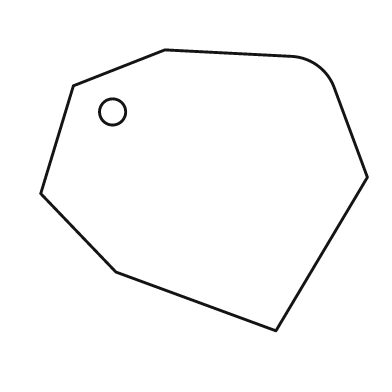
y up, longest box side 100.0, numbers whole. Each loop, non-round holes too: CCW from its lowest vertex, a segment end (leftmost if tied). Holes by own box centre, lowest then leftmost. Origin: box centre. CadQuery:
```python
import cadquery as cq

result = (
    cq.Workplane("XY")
    .moveTo(22.0, -43.0)
    .lineTo(50.0, 4.0)
    .lineTo(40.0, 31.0)
    .threePointArc((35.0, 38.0), (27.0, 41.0))
    .lineTo(-12.0, 43.0)
    .lineTo(-40.0, 32.0)
    .lineTo(-50.0, -1.0)
    .lineTo(-27.0, -25.0)
    .close()
    .moveTo(-28.0, 24.0)
    .circle(4.0)
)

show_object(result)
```